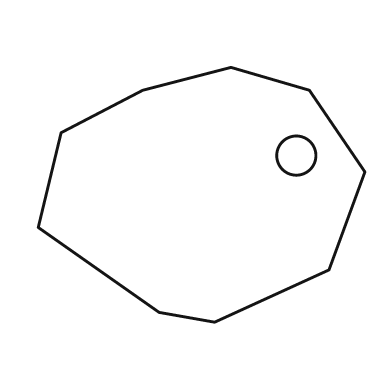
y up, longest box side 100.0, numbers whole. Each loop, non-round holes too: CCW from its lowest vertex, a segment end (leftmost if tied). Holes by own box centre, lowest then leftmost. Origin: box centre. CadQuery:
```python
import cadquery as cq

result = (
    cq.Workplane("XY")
    .moveTo(4.0, -39.0)
    .lineTo(39.0, -23.0)
    .lineTo(50.0, 7.0)
    .lineTo(33.0, 32.0)
    .lineTo(9.0, 39.0)
    .lineTo(-18.0, 32.0)
    .lineTo(-43.0, 19.0)
    .lineTo(-50.0, -10.0)
    .lineTo(-13.0, -36.0)
    .close()
    .moveTo(29.0, 12.0)
    .circle(6.0)
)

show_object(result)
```